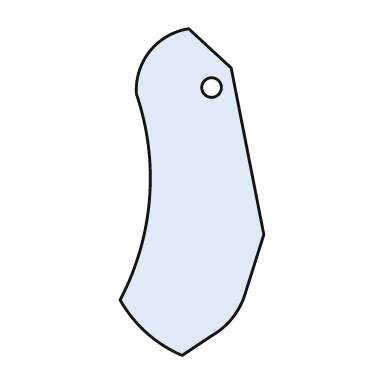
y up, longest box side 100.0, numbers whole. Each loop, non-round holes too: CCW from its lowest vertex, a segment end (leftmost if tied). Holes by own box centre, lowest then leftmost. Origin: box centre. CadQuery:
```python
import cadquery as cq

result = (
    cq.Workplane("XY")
    .moveTo(-3.0, -50.0)
    .lineTo(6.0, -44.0)
    .threePointArc((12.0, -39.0), (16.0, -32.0))
    .lineTo(22.0, -13.0)
    .lineTo(12.0, 38.0)
    .lineTo(-1.0, 50.0)
    .threePointArc((-13.0, 43.0), (-17.0, 30.0))
    .threePointArc((-13.0, -2.0), (-22.0, -33.0))
    .threePointArc((-14.0, -43.0), (-3.0, -50.0))
    .close()
    .moveTo(6.0, 32.0)
    .circle(3.0)
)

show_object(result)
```